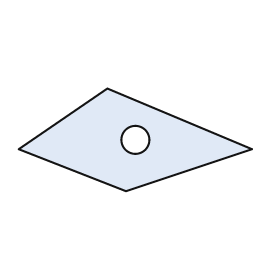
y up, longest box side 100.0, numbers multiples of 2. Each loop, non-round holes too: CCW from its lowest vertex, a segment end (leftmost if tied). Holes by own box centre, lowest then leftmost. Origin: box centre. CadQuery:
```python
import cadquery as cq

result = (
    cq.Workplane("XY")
    .moveTo(-4.0, -22.0)
    .lineTo(50.0, -4.0)
    .lineTo(-12.0, 22.0)
    .lineTo(-50.0, -4.0)
    .close()
    .moveTo(0.0, 0.0)
    .circle(6.0)
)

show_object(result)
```